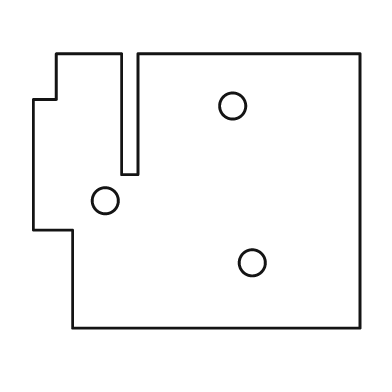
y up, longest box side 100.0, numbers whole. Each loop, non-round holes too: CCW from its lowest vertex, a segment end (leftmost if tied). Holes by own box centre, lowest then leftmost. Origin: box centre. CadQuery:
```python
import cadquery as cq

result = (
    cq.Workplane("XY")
    .moveTo(-38.0, -42.0)
    .lineTo(50.0, -42.0)
    .lineTo(50.0, 42.0)
    .lineTo(-18.0, 42.0)
    .lineTo(-18.0, 5.0)
    .lineTo(-23.0, 5.0)
    .lineTo(-23.0, 42.0)
    .lineTo(-43.0, 42.0)
    .lineTo(-43.0, 28.0)
    .lineTo(-50.0, 28.0)
    .lineTo(-50.0, -12.0)
    .lineTo(-38.0, -12.0)
    .close()
    .moveTo(17.0, -22.0)
    .circle(4.0)
    .moveTo(-28.0, -3.0)
    .circle(4.0)
    .moveTo(11.0, 26.0)
    .circle(4.0)
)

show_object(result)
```